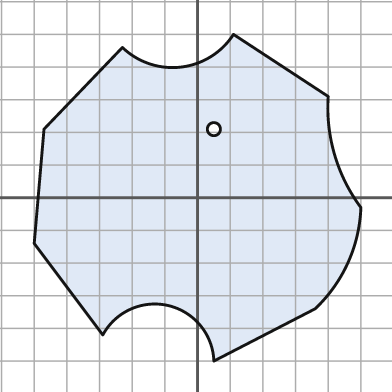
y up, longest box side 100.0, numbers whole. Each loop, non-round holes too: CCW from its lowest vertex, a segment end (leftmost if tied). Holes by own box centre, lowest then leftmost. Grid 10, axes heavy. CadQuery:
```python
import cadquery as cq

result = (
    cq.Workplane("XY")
    .moveTo(5.0, -50.0)
    .lineTo(36.0, -34.0)
    .threePointArc((46.0, -20.0), (50.0, -3.0))
    .threePointArc((42.0, 13.0), (40.0, 31.0))
    .lineTo(11.0, 50.0)
    .threePointArc((-5.0, 40.0), (-23.0, 46.0))
    .lineTo(-47.0, 21.0)
    .lineTo(-50.0, -14.0)
    .lineTo(-29.0, -42.0)
    .threePointArc((-9.0, -33.0), (5.0, -50.0))
    .close()
    .moveTo(5.0, 21.0)
    .circle(2.0)
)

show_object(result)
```